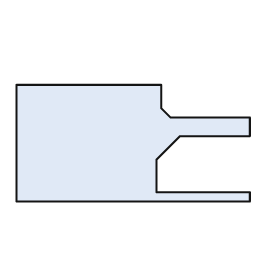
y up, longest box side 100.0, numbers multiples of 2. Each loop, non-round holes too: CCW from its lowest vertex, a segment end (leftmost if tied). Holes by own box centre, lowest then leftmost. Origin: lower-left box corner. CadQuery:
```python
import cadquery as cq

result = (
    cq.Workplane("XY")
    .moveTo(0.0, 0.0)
    .lineTo(100.0, 0.0)
    .lineTo(100.0, 4.0)
    .lineTo(60.0, 4.0)
    .lineTo(60.0, 18.0)
    .lineTo(70.0, 28.0)
    .lineTo(100.0, 28.0)
    .lineTo(100.0, 36.0)
    .lineTo(66.0, 36.0)
    .lineTo(62.0, 40.0)
    .lineTo(62.0, 50.0)
    .lineTo(0.0, 50.0)
    .close()
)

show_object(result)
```